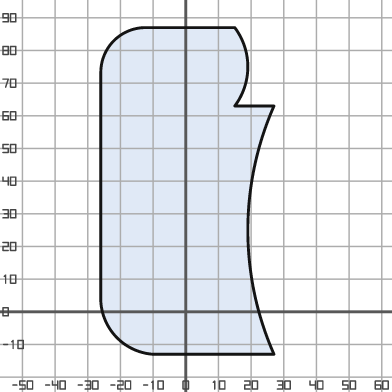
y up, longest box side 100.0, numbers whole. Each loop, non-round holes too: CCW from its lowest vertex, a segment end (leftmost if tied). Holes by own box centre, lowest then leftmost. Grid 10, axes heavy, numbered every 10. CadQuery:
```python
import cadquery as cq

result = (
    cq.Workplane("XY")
    .moveTo(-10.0, -13.0)
    .lineTo(27.0, -13.0)
    .threePointArc((19.0, 25.0), (27.0, 63.0))
    .lineTo(15.0, 63.0)
    .threePointArc((19.0, 75.0), (15.0, 87.0))
    .lineTo(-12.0, 87.0)
    .threePointArc((-22.0, 83.0), (-26.0, 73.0))
    .lineTo(-26.0, 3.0)
    .threePointArc((-21.0, -8.0), (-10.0, -13.0))
    .close()
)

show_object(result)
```